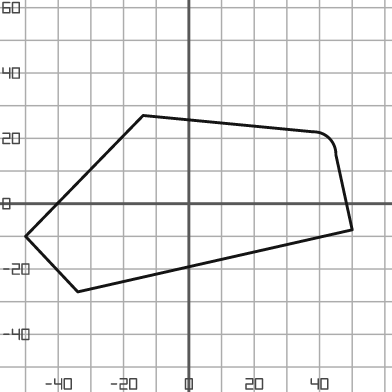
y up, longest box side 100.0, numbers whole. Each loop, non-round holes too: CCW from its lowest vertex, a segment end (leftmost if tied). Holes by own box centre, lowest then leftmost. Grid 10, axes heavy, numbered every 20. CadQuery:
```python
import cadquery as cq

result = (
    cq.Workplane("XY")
    .moveTo(-34.0, -27.0)
    .lineTo(50.0, -8.0)
    .lineTo(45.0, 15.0)
    .threePointArc((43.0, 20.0), (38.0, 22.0))
    .lineTo(-14.0, 27.0)
    .lineTo(-50.0, -10.0)
    .close()
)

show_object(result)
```